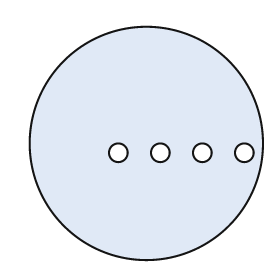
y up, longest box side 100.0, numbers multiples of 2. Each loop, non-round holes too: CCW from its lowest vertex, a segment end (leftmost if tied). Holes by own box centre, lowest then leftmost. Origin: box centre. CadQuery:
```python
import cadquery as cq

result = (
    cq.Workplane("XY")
    .moveTo(0.0, 0.0)
    .circle(50.0)
    .moveTo(-12.0, -4.0)
    .circle(4.0)
    .moveTo(6.0, -4.0)
    .circle(4.0)
    .moveTo(24.0, -4.0)
    .circle(4.0)
    .moveTo(42.0, -4.0)
    .circle(4.0)
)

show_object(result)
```